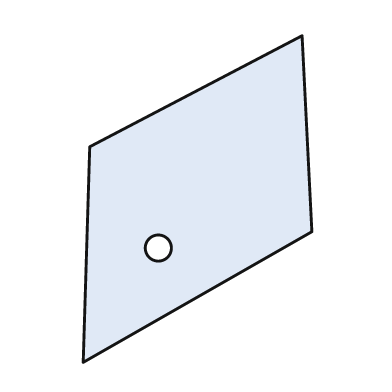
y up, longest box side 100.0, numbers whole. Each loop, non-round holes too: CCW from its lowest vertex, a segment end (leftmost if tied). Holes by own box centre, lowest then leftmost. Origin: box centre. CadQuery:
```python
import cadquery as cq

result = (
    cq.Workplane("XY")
    .moveTo(-35.0, -50.0)
    .lineTo(35.0, -10.0)
    .lineTo(32.0, 50.0)
    .lineTo(-33.0, 16.0)
    .close()
    .moveTo(-12.0, -15.0)
    .circle(4.0)
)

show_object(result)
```